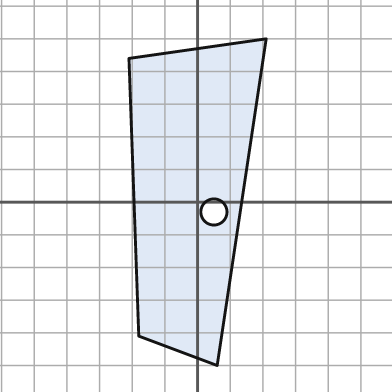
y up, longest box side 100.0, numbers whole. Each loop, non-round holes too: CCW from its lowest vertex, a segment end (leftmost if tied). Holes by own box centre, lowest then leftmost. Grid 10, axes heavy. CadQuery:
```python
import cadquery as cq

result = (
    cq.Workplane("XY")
    .moveTo(6.0, -50.0)
    .lineTo(21.0, 50.0)
    .lineTo(-21.0, 44.0)
    .lineTo(-18.0, -41.0)
    .close()
    .moveTo(5.0, -3.0)
    .circle(4.0)
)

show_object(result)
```